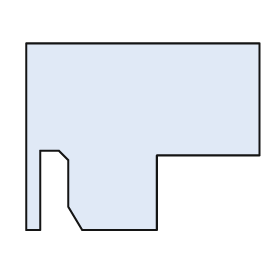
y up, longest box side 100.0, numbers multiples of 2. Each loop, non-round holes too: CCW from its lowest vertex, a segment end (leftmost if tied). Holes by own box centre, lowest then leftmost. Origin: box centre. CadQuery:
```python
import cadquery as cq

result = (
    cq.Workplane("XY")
    .moveTo(-50.0, -40.0)
    .lineTo(-44.0, -40.0)
    .lineTo(-44.0, -6.0)
    .lineTo(-36.0, -6.0)
    .lineTo(-32.0, -10.0)
    .lineTo(-32.0, -30.0)
    .lineTo(-26.0, -40.0)
    .lineTo(6.0, -40.0)
    .lineTo(6.0, -8.0)
    .lineTo(50.0, -8.0)
    .lineTo(50.0, 40.0)
    .lineTo(-50.0, 40.0)
    .close()
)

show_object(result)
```